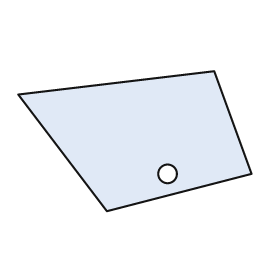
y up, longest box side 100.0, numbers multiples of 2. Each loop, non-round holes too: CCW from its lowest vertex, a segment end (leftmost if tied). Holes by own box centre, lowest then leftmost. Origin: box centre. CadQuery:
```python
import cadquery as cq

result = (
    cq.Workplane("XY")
    .moveTo(-12.0, -30.0)
    .lineTo(50.0, -14.0)
    .lineTo(34.0, 30.0)
    .lineTo(-50.0, 20.0)
    .close()
    .moveTo(14.0, -14.0)
    .circle(4.0)
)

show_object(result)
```